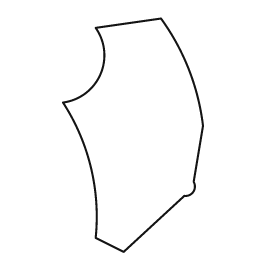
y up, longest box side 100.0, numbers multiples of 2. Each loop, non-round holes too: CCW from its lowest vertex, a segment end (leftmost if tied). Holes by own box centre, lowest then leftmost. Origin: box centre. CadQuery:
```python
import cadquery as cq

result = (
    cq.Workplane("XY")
    .moveTo(-4.0, -50.0)
    .lineTo(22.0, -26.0)
    .threePointArc((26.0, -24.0), (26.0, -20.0))
    .lineTo(30.0, 4.0)
    .threePointArc((24.0, 28.0), (12.0, 50.0))
    .lineTo(-16.0, 46.0)
    .threePointArc((-14.0, 26.0), (-30.0, 14.0))
    .threePointArc((-18.0, -14.0), (-16.0, -44.0))
    .close()
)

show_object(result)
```